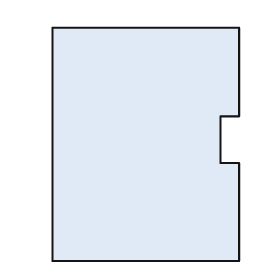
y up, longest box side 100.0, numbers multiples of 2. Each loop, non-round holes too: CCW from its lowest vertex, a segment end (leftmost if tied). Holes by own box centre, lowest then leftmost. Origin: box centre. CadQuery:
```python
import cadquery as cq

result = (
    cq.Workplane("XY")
    .moveTo(-40.0, -50.0)
    .lineTo(40.0, -50.0)
    .lineTo(40.0, -8.0)
    .lineTo(32.0, -8.0)
    .lineTo(32.0, 12.0)
    .lineTo(40.0, 12.0)
    .lineTo(40.0, 50.0)
    .lineTo(-40.0, 50.0)
    .close()
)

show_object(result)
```